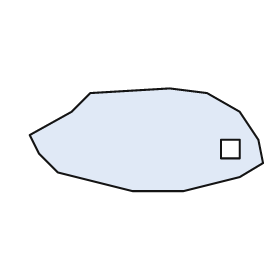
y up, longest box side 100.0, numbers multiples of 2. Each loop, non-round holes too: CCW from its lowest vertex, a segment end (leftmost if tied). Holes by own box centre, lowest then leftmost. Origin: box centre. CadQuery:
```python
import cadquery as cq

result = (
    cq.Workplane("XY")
    .moveTo(-6.0, -22.0)
    .lineTo(16.0, -22.0)
    .lineTo(40.0, -16.0)
    .lineTo(50.0, -10.0)
    .lineTo(48.0, 0.0)
    .lineTo(40.0, 12.0)
    .lineTo(26.0, 20.0)
    .lineTo(10.0, 22.0)
    .lineTo(-24.0, 20.0)
    .lineTo(-32.0, 12.0)
    .lineTo(-50.0, 2.0)
    .lineTo(-46.0, -6.0)
    .lineTo(-38.0, -14.0)
    .close()
    .moveTo(32.0, -8.0)
    .lineTo(40.0, -8.0)
    .lineTo(40.0, 0.0)
    .lineTo(32.0, 0.0)
    .close()
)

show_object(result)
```